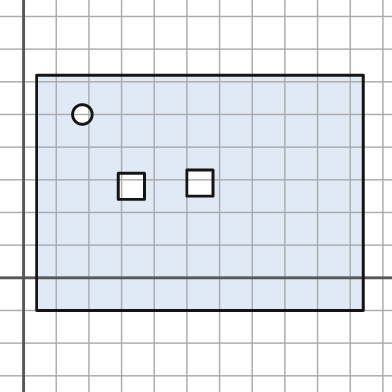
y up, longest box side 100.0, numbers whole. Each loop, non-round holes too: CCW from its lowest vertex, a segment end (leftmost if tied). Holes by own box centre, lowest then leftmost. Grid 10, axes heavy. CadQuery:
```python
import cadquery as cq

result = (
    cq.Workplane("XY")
    .moveTo(4.0, -10.0)
    .lineTo(104.0, -10.0)
    .lineTo(104.0, 62.0)
    .lineTo(4.0, 62.0)
    .close()
    .moveTo(29.0, 24.0)
    .lineTo(37.0, 24.0)
    .lineTo(37.0, 32.0)
    .lineTo(29.0, 32.0)
    .close()
    .moveTo(50.0, 25.0)
    .lineTo(58.0, 25.0)
    .lineTo(58.0, 33.0)
    .lineTo(50.0, 33.0)
    .close()
    .moveTo(18.0, 50.0)
    .circle(3.0)
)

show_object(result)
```